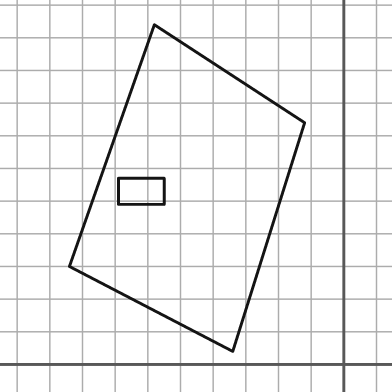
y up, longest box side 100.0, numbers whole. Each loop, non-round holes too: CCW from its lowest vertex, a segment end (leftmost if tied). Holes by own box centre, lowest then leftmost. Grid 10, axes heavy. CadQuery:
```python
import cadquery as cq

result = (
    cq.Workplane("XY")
    .moveTo(-34.0, 4.0)
    .lineTo(-12.0, 74.0)
    .lineTo(-58.0, 104.0)
    .lineTo(-84.0, 30.0)
    .close()
    .moveTo(-69.0, 49.0)
    .lineTo(-55.0, 49.0)
    .lineTo(-55.0, 57.0)
    .lineTo(-69.0, 57.0)
    .close()
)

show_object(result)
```